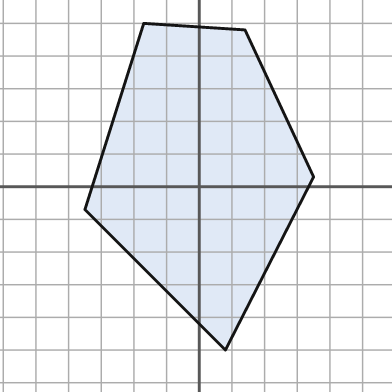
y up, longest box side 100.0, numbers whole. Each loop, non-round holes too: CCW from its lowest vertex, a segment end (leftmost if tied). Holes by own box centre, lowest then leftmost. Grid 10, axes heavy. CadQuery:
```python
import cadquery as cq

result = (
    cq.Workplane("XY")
    .moveTo(8.0, -50.0)
    .lineTo(35.0, 3.0)
    .lineTo(14.0, 48.0)
    .lineTo(-17.0, 50.0)
    .lineTo(-35.0, -7.0)
    .close()
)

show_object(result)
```